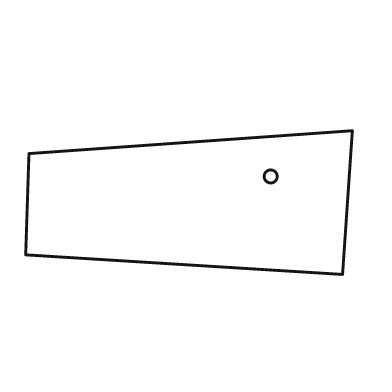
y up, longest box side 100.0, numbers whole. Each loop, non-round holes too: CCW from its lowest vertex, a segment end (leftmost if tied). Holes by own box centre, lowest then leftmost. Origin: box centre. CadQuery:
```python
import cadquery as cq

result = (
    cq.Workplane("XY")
    .moveTo(47.0, -22.0)
    .lineTo(50.0, 22.0)
    .lineTo(-49.0, 15.0)
    .lineTo(-50.0, -16.0)
    .close()
    .moveTo(25.0, 8.0)
    .circle(2.0)
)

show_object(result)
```